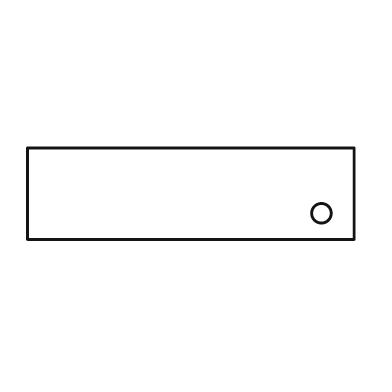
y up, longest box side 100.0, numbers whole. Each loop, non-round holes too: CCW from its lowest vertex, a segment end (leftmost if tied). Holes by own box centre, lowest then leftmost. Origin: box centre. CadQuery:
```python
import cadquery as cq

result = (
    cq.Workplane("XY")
    .moveTo(-50.0, -14.0)
    .lineTo(50.0, -14.0)
    .lineTo(50.0, 14.0)
    .lineTo(-50.0, 14.0)
    .close()
    .moveTo(40.0, -6.0)
    .circle(3.0)
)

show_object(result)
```